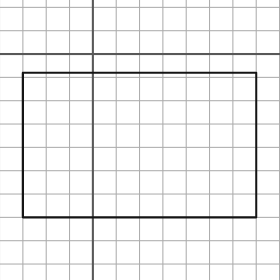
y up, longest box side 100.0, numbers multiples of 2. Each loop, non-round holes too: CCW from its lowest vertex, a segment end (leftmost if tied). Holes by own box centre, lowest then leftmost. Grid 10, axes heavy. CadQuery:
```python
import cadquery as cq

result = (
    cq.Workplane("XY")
    .moveTo(-30.0, -70.0)
    .lineTo(70.0, -70.0)
    .lineTo(70.0, -8.0)
    .lineTo(-30.0, -8.0)
    .close()
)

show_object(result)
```